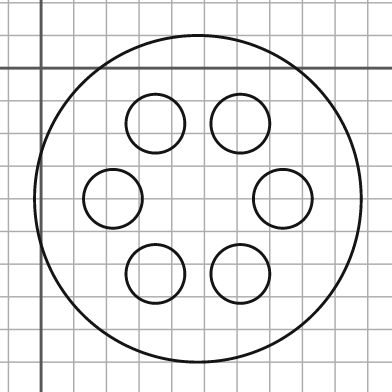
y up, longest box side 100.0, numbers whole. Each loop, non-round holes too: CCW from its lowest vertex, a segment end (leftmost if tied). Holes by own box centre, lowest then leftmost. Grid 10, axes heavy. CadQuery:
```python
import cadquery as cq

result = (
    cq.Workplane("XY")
    .moveTo(48.0, -40.0)
    .circle(50.0)
    .moveTo(35.0, -63.0)
    .circle(9.0)
    .moveTo(61.0, -63.0)
    .circle(9.0)
    .moveTo(22.0, -40.0)
    .circle(9.0)
    .moveTo(74.0, -40.0)
    .circle(9.0)
    .moveTo(35.0, -17.0)
    .circle(9.0)
    .moveTo(61.0, -17.0)
    .circle(9.0)
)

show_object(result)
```